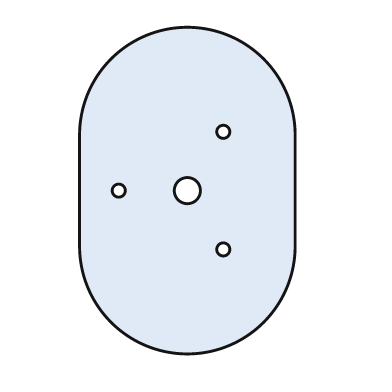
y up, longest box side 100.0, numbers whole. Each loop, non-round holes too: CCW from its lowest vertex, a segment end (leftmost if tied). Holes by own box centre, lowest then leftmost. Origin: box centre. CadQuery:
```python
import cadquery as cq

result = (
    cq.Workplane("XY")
    .moveTo(-33.0, -17.0)
    .threePointArc((0.0, -50.0), (33.0, -17.0))
    .lineTo(33.0, 17.0)
    .threePointArc((0.0, 50.0), (-33.0, 17.0))
    .close()
    .moveTo(11.0, -18.0)
    .circle(2.0)
    .moveTo(-21.0, 0.0)
    .circle(2.0)
    .moveTo(0.0, 0.0)
    .circle(4.0)
    .moveTo(11.0, 18.0)
    .circle(2.0)
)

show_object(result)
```